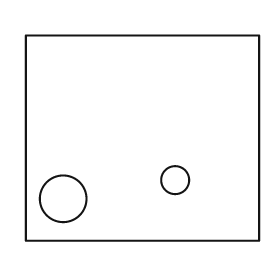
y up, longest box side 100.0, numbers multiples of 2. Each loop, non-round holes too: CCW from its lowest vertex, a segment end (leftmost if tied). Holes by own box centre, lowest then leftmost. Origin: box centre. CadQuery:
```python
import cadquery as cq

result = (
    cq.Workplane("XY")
    .moveTo(-50.0, -44.0)
    .lineTo(50.0, -44.0)
    .lineTo(50.0, 44.0)
    .lineTo(-50.0, 44.0)
    .close()
    .moveTo(-34.0, -26.0)
    .circle(10.0)
    .moveTo(14.0, -18.0)
    .circle(6.0)
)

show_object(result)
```